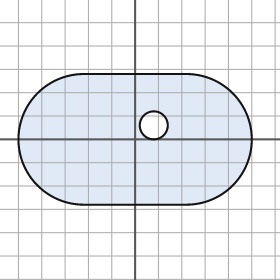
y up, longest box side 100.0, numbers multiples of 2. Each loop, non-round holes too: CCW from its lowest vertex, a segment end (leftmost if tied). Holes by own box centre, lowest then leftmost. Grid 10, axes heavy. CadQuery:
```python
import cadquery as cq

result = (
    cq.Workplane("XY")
    .moveTo(-22.0, -28.0)
    .lineTo(22.0, -28.0)
    .threePointArc((50.0, 0.0), (22.0, 28.0))
    .lineTo(-22.0, 28.0)
    .threePointArc((-50.0, 0.0), (-22.0, -28.0))
    .close()
    .moveTo(8.0, 6.0)
    .circle(6.0)
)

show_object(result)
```